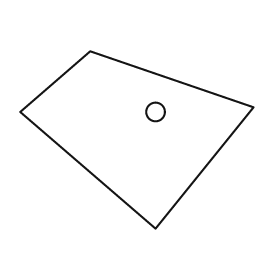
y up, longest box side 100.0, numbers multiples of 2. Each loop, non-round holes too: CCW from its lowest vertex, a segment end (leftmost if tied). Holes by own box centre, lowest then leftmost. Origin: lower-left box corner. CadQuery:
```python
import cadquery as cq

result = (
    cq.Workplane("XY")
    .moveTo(58.0, 0.0)
    .lineTo(100.0, 52.0)
    .lineTo(30.0, 76.0)
    .lineTo(0.0, 50.0)
    .close()
    .moveTo(58.0, 50.0)
    .circle(4.0)
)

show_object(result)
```